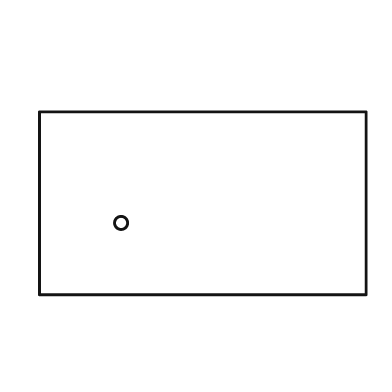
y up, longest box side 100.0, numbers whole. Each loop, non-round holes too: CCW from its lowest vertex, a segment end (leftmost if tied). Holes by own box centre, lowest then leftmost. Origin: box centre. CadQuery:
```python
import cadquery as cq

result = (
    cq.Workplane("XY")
    .moveTo(-50.0, -28.0)
    .lineTo(50.0, -28.0)
    .lineTo(50.0, 28.0)
    .lineTo(-50.0, 28.0)
    .close()
    .moveTo(-25.0, -6.0)
    .circle(2.0)
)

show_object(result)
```